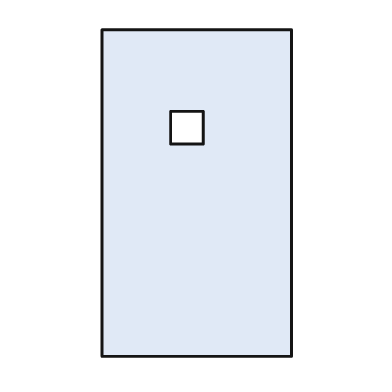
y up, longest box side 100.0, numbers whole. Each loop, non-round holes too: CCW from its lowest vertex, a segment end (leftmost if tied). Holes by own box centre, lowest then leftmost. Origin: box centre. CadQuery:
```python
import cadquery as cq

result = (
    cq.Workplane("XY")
    .moveTo(-29.0, -50.0)
    .lineTo(29.0, -50.0)
    .lineTo(29.0, 50.0)
    .lineTo(-29.0, 50.0)
    .close()
    .moveTo(-8.0, 15.0)
    .lineTo(2.0, 15.0)
    .lineTo(2.0, 25.0)
    .lineTo(-8.0, 25.0)
    .close()
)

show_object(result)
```